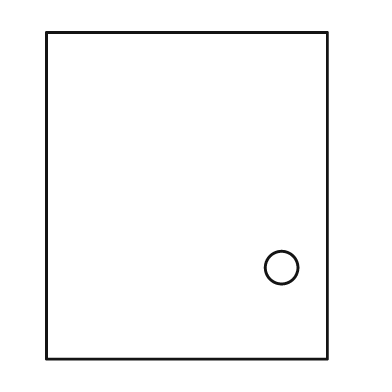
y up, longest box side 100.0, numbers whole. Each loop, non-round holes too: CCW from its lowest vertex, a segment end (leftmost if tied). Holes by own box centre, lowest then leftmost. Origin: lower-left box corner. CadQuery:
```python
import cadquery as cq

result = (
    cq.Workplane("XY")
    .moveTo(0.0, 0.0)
    .lineTo(86.0, 0.0)
    .lineTo(86.0, 100.0)
    .lineTo(0.0, 100.0)
    .close()
    .moveTo(72.0, 28.0)
    .circle(5.0)
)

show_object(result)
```